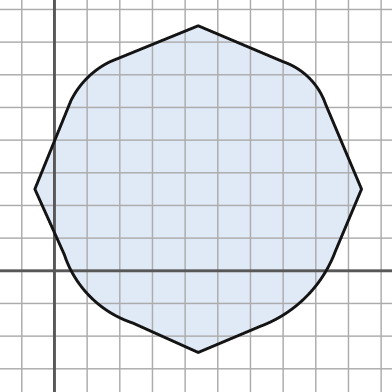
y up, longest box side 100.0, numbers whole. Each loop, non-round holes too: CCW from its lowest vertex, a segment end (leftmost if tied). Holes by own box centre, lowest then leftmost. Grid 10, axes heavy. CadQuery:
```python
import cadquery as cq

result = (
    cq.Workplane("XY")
    .moveTo(44.0, -25.0)
    .lineTo(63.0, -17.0)
    .threePointArc((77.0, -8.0), (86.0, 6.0))
    .lineTo(94.0, 25.0)
    .lineTo(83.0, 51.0)
    .threePointArc((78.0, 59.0), (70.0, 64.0))
    .lineTo(44.0, 75.0)
    .lineTo(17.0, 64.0)
    .threePointArc((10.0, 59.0), (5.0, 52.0))
    .lineTo(-6.0, 25.0)
    .lineTo(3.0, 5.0)
    .threePointArc((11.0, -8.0), (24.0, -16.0))
    .close()
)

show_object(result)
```